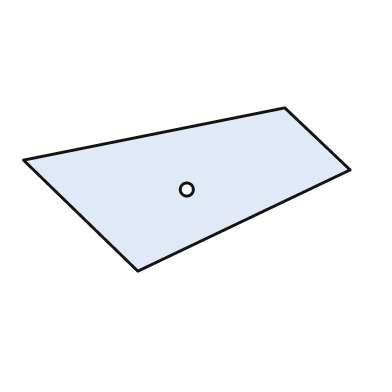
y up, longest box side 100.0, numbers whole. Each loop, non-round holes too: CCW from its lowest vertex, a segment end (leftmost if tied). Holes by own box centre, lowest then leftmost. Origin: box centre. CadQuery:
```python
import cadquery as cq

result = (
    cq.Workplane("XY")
    .moveTo(-15.0, -25.0)
    .lineTo(50.0, 6.0)
    .lineTo(30.0, 25.0)
    .lineTo(-50.0, 9.0)
    .close()
    .moveTo(0.0, 0.0)
    .circle(2.0)
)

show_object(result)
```